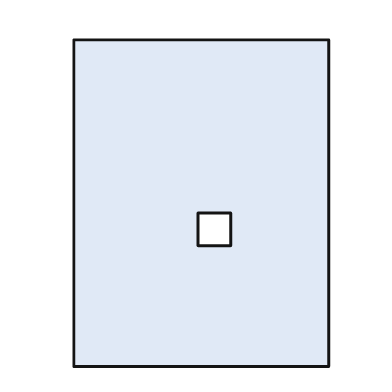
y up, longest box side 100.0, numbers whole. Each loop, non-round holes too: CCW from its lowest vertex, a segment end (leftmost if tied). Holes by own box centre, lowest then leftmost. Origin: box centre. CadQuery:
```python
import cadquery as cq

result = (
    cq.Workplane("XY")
    .moveTo(-39.0, -50.0)
    .lineTo(39.0, -50.0)
    .lineTo(39.0, 50.0)
    .lineTo(-39.0, 50.0)
    .close()
    .moveTo(-1.0, -13.0)
    .lineTo(9.0, -13.0)
    .lineTo(9.0, -3.0)
    .lineTo(-1.0, -3.0)
    .close()
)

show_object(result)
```